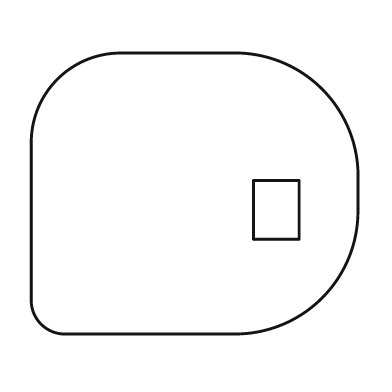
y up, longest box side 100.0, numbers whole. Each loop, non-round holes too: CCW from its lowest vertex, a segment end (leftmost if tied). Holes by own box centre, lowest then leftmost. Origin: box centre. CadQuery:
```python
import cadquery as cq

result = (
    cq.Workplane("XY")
    .moveTo(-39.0, -43.0)
    .lineTo(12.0, -43.0)
    .threePointArc((39.0, -32.0), (50.0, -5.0))
    .lineTo(50.0, 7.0)
    .threePointArc((39.0, 32.0), (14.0, 43.0))
    .lineTo(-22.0, 43.0)
    .threePointArc((-42.0, 35.0), (-50.0, 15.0))
    .lineTo(-50.0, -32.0)
    .threePointArc((-47.0, -40.0), (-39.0, -43.0))
    .close()
    .moveTo(18.0, -14.0)
    .lineTo(32.0, -14.0)
    .lineTo(32.0, 4.0)
    .lineTo(18.0, 4.0)
    .close()
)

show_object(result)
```